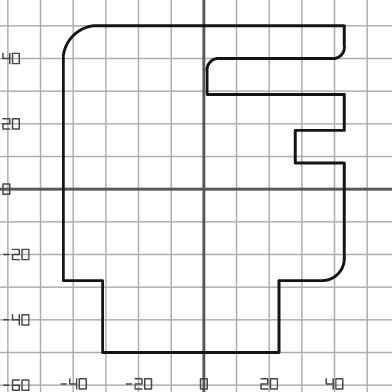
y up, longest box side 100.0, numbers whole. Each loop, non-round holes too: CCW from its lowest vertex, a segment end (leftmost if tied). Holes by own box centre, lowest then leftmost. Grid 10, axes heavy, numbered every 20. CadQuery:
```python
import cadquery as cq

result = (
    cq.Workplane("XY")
    .moveTo(-31.0, -50.0)
    .lineTo(23.0, -50.0)
    .lineTo(23.0, -28.0)
    .lineTo(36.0, -28.0)
    .threePointArc((41.0, -26.0), (43.0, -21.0))
    .lineTo(43.0, 8.0)
    .lineTo(28.0, 8.0)
    .lineTo(28.0, 18.0)
    .lineTo(43.0, 18.0)
    .lineTo(43.0, 29.0)
    .lineTo(1.0, 29.0)
    .lineTo(1.0, 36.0)
    .threePointArc((2.0, 39.0), (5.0, 40.0))
    .lineTo(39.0, 40.0)
    .threePointArc((42.0, 41.0), (43.0, 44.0))
    .lineTo(43.0, 50.0)
    .lineTo(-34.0, 50.0)
    .threePointArc((-40.0, 47.0), (-43.0, 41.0))
    .lineTo(-43.0, -28.0)
    .lineTo(-31.0, -28.0)
    .close()
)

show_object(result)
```